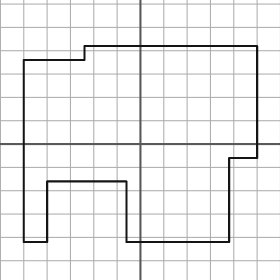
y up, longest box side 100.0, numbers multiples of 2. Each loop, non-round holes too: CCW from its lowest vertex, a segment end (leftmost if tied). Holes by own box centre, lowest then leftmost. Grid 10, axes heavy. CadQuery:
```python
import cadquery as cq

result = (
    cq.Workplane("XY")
    .moveTo(-50.0, -42.0)
    .lineTo(-40.0, -42.0)
    .lineTo(-40.0, -16.0)
    .lineTo(-6.0, -16.0)
    .lineTo(-6.0, -42.0)
    .lineTo(38.0, -42.0)
    .lineTo(38.0, -6.0)
    .lineTo(50.0, -6.0)
    .lineTo(50.0, 42.0)
    .lineTo(-24.0, 42.0)
    .lineTo(-24.0, 36.0)
    .lineTo(-50.0, 36.0)
    .close()
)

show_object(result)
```